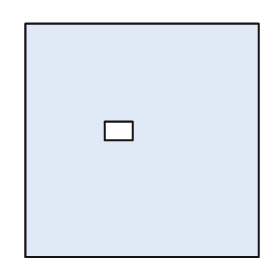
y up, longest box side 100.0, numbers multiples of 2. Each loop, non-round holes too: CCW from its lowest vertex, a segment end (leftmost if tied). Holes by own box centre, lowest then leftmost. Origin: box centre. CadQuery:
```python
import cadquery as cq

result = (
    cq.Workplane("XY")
    .moveTo(-50.0, -50.0)
    .lineTo(50.0, -50.0)
    .lineTo(50.0, 50.0)
    .lineTo(-50.0, 50.0)
    .close()
    .moveTo(-16.0, 0.0)
    .lineTo(-4.0, 0.0)
    .lineTo(-4.0, 8.0)
    .lineTo(-16.0, 8.0)
    .close()
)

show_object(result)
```